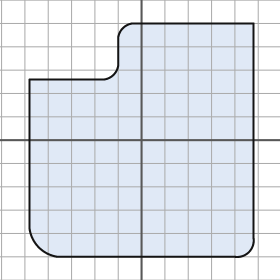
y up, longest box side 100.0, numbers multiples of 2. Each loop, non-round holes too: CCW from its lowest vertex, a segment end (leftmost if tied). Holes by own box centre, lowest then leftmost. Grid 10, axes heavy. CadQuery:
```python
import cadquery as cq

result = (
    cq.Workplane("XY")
    .moveTo(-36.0, -50.0)
    .lineTo(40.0, -50.0)
    .threePointArc((46.0, -48.0), (48.0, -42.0))
    .lineTo(48.0, 50.0)
    .lineTo(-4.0, 50.0)
    .threePointArc((-8.0, 48.0), (-10.0, 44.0))
    .lineTo(-10.0, 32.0)
    .threePointArc((-12.0, 28.0), (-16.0, 26.0))
    .lineTo(-48.0, 26.0)
    .lineTo(-48.0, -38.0)
    .threePointArc((-44.0, -46.0), (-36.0, -50.0))
    .close()
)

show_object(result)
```